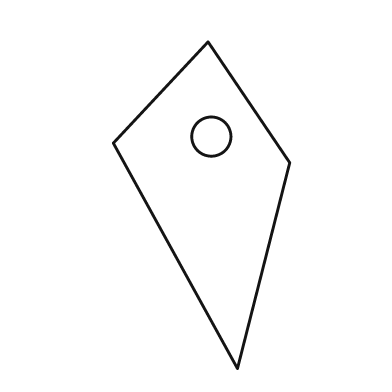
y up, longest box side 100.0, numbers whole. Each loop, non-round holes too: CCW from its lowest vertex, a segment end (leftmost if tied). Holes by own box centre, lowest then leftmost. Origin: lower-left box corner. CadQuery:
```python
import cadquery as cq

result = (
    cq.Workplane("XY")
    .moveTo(38.0, 0.0)
    .lineTo(54.0, 63.0)
    .lineTo(29.0, 100.0)
    .lineTo(0.0, 69.0)
    .close()
    .moveTo(30.0, 71.0)
    .circle(6.0)
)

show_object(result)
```